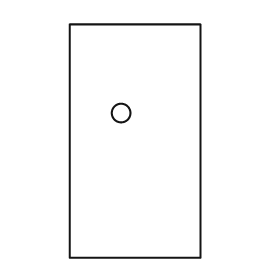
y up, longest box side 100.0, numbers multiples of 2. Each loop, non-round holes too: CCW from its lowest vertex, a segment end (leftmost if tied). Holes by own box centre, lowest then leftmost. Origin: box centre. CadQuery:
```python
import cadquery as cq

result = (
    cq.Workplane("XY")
    .moveTo(-28.0, -50.0)
    .lineTo(28.0, -50.0)
    .lineTo(28.0, 50.0)
    .lineTo(-28.0, 50.0)
    .close()
    .moveTo(-6.0, 12.0)
    .circle(4.0)
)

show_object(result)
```